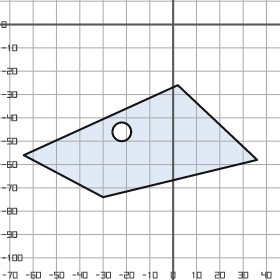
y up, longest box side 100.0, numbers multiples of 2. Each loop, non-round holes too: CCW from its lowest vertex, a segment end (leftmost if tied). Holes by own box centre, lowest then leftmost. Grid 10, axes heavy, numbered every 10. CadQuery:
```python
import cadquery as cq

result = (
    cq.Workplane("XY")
    .moveTo(-30.0, -74.0)
    .lineTo(36.0, -58.0)
    .lineTo(2.0, -26.0)
    .lineTo(-64.0, -56.0)
    .close()
    .moveTo(-22.0, -46.0)
    .circle(4.0)
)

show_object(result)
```